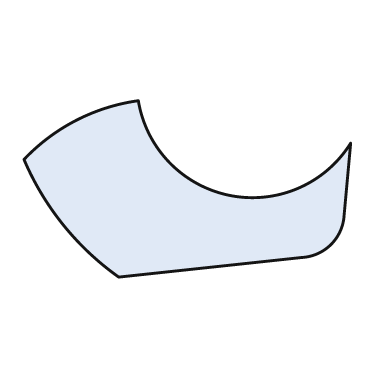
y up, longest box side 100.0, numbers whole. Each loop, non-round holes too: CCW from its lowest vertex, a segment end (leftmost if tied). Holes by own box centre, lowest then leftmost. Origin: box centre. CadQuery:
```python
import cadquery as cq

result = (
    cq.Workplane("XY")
    .moveTo(-21.0, -27.0)
    .lineTo(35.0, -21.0)
    .threePointArc((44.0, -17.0), (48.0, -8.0))
    .lineTo(50.0, 14.0)
    .threePointArc((13.0, -2.0), (-15.0, 27.0))
    .threePointArc((-34.0, 21.0), (-50.0, 9.0))
    .threePointArc((-38.0, -11.0), (-21.0, -27.0))
    .close()
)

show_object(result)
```